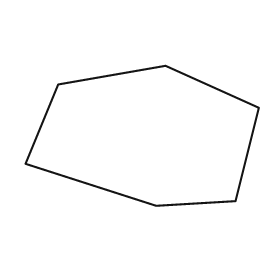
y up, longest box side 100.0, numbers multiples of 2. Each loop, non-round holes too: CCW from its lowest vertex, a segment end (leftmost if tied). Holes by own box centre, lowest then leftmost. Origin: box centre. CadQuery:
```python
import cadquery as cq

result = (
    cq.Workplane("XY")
    .moveTo(6.0, -30.0)
    .lineTo(40.0, -28.0)
    .lineTo(50.0, 12.0)
    .lineTo(10.0, 30.0)
    .lineTo(-36.0, 22.0)
    .lineTo(-50.0, -12.0)
    .close()
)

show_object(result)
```